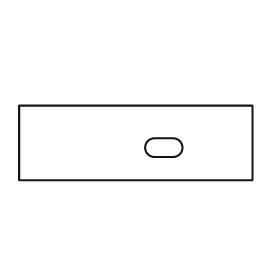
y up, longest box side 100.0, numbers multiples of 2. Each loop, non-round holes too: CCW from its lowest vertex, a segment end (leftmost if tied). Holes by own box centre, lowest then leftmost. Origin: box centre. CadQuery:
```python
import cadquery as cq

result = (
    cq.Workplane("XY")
    .moveTo(-50.0, -16.0)
    .lineTo(50.0, -16.0)
    .lineTo(50.0, 16.0)
    .lineTo(-50.0, 16.0)
    .close()
    .moveTo(8.0, -6.0)
    .lineTo(16.0, -6.0)
    .threePointArc((20.0, -2.0), (16.0, 2.0))
    .lineTo(8.0, 2.0)
    .threePointArc((4.0, -2.0), (8.0, -6.0))
    .close()
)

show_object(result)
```